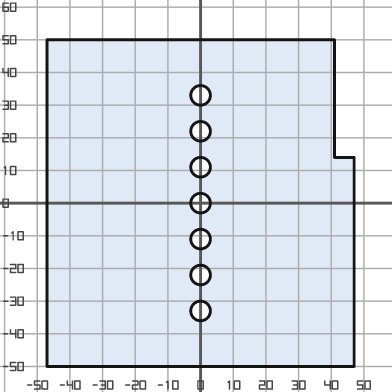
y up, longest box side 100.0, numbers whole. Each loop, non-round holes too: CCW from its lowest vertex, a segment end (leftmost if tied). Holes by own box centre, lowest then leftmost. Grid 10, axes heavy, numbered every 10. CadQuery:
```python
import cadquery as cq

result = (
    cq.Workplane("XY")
    .moveTo(-47.0, -50.0)
    .lineTo(47.0, -50.0)
    .lineTo(47.0, 14.0)
    .lineTo(41.0, 14.0)
    .lineTo(41.0, 50.0)
    .lineTo(-47.0, 50.0)
    .close()
    .moveTo(0.0, -33.0)
    .circle(3.0)
    .moveTo(0.0, -22.0)
    .circle(3.0)
    .moveTo(0.0, -11.0)
    .circle(3.0)
    .moveTo(0.0, 0.0)
    .circle(3.0)
    .moveTo(0.0, 11.0)
    .circle(3.0)
    .moveTo(0.0, 22.0)
    .circle(3.0)
    .moveTo(0.0, 33.0)
    .circle(3.0)
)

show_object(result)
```